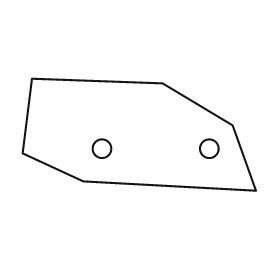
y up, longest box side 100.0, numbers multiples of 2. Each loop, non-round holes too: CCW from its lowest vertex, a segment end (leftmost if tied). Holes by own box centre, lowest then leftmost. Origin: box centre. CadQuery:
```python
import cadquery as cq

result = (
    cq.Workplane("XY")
    .moveTo(50.0, -24.0)
    .lineTo(40.0, 4.0)
    .lineTo(10.0, 22.0)
    .lineTo(-46.0, 24.0)
    .lineTo(-50.0, -8.0)
    .lineTo(-24.0, -20.0)
    .close()
    .moveTo(-16.0, -6.0)
    .circle(4.0)
    .moveTo(30.0, -6.0)
    .circle(4.0)
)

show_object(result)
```